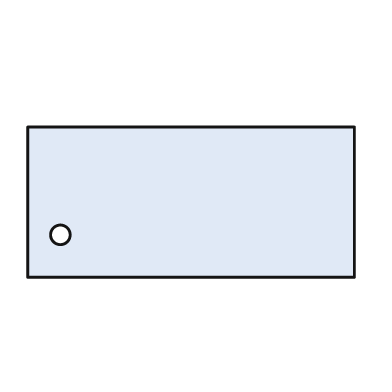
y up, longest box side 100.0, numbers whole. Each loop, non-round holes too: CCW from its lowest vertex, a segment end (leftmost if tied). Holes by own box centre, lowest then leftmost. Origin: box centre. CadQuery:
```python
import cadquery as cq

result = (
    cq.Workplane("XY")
    .moveTo(-50.0, -23.0)
    .lineTo(50.0, -23.0)
    .lineTo(50.0, 23.0)
    .lineTo(-50.0, 23.0)
    .close()
    .moveTo(-40.0, -10.0)
    .circle(3.0)
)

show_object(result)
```